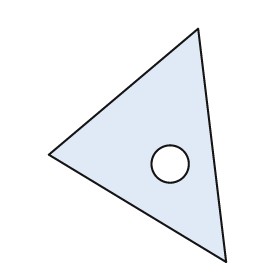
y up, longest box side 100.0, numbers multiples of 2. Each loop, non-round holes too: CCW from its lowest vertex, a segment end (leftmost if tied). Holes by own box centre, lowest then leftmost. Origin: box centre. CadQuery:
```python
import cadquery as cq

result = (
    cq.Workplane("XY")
    .moveTo(38.0, -50.0)
    .lineTo(26.0, 50.0)
    .lineTo(-38.0, -4.0)
    .close()
    .moveTo(14.0, -8.0)
    .circle(8.0)
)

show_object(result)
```